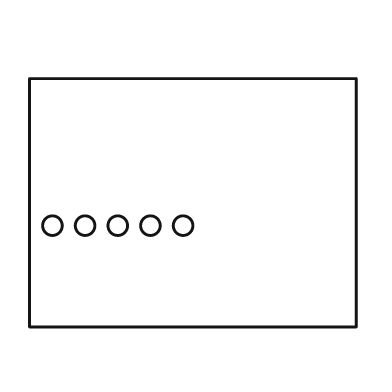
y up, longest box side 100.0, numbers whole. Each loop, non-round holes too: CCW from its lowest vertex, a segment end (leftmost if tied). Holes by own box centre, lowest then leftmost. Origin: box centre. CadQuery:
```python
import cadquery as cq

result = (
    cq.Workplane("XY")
    .moveTo(-50.0, -38.0)
    .lineTo(50.0, -38.0)
    .lineTo(50.0, 38.0)
    .lineTo(-50.0, 38.0)
    .close()
    .moveTo(-43.0, -7.0)
    .circle(3.0)
    .moveTo(-33.0, -7.0)
    .circle(3.0)
    .moveTo(-23.0, -7.0)
    .circle(3.0)
    .moveTo(-13.0, -7.0)
    .circle(3.0)
    .moveTo(-3.0, -7.0)
    .circle(3.0)
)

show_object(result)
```